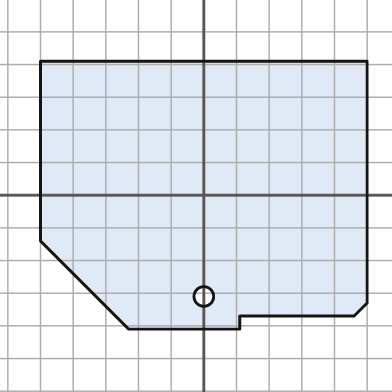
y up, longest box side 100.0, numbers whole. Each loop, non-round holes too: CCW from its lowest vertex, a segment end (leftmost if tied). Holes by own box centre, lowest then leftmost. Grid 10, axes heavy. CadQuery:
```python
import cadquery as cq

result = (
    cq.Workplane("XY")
    .moveTo(-23.0, -41.0)
    .lineTo(11.0, -41.0)
    .lineTo(11.0, -37.0)
    .lineTo(46.0, -37.0)
    .lineTo(50.0, -33.0)
    .lineTo(50.0, 41.0)
    .lineTo(-50.0, 41.0)
    .lineTo(-50.0, -14.0)
    .close()
    .moveTo(0.0, -31.0)
    .circle(3.0)
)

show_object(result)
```